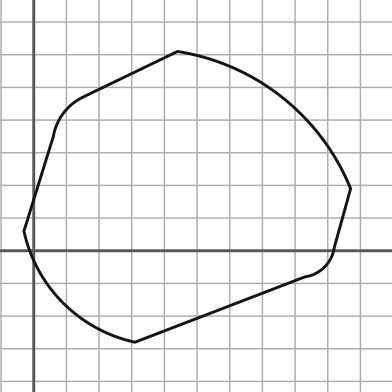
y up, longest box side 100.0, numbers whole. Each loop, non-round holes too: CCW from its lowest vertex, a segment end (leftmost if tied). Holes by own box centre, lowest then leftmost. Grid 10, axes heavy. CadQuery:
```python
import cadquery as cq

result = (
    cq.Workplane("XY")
    .moveTo(31.0, -28.0)
    .lineTo(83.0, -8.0)
    .threePointArc((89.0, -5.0), (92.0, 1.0))
    .lineTo(97.0, 19.0)
    .threePointArc((76.0, 47.0), (44.0, 61.0))
    .lineTo(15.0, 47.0)
    .threePointArc((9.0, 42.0), (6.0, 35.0))
    .lineTo(-3.0, 6.0)
    .threePointArc((9.0, -16.0), (31.0, -28.0))
    .close()
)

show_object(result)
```